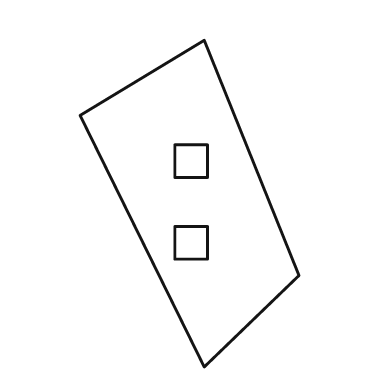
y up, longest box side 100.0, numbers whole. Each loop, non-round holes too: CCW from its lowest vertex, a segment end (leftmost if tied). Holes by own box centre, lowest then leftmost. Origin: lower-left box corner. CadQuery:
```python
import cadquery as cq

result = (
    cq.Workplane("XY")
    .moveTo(38.0, 0.0)
    .lineTo(67.0, 28.0)
    .lineTo(38.0, 100.0)
    .lineTo(0.0, 77.0)
    .close()
    .moveTo(29.0, 33.0)
    .lineTo(39.0, 33.0)
    .lineTo(39.0, 43.0)
    .lineTo(29.0, 43.0)
    .close()
    .moveTo(29.0, 58.0)
    .lineTo(39.0, 58.0)
    .lineTo(39.0, 68.0)
    .lineTo(29.0, 68.0)
    .close()
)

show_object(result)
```